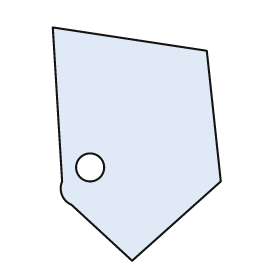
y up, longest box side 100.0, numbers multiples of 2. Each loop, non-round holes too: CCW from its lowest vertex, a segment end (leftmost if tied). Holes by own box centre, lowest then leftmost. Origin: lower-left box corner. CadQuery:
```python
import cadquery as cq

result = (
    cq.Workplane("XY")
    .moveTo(34.0, 0.0)
    .lineTo(72.0, 34.0)
    .lineTo(66.0, 90.0)
    .lineTo(0.0, 100.0)
    .lineTo(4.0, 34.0)
    .threePointArc((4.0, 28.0), (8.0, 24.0))
    .close()
    .moveTo(16.0, 40.0)
    .circle(6.0)
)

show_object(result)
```